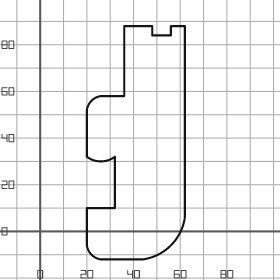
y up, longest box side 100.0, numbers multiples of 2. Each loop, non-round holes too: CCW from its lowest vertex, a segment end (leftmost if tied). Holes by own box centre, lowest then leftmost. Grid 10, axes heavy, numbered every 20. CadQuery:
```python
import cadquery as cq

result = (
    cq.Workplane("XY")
    .moveTo(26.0, -12.0)
    .lineTo(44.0, -12.0)
    .threePointArc((56.0, -6.0), (62.0, 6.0))
    .lineTo(62.0, 88.0)
    .lineTo(56.0, 88.0)
    .lineTo(56.0, 84.0)
    .lineTo(48.0, 84.0)
    .lineTo(48.0, 88.0)
    .lineTo(36.0, 88.0)
    .lineTo(36.0, 58.0)
    .lineTo(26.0, 58.0)
    .threePointArc((22.0, 56.0), (20.0, 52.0))
    .lineTo(20.0, 32.0)
    .threePointArc((26.0, 30.0), (32.0, 32.0))
    .lineTo(32.0, 10.0)
    .lineTo(20.0, 10.0)
    .lineTo(20.0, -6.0)
    .threePointArc((22.0, -10.0), (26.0, -12.0))
    .close()
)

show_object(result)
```